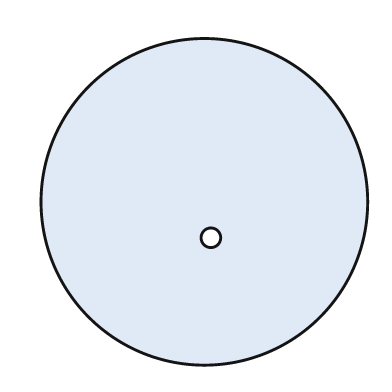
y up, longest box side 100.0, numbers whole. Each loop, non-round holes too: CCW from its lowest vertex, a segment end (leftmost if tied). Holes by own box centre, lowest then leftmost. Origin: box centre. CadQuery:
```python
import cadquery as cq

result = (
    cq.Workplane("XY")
    .moveTo(0.0, 0.0)
    .circle(50.0)
    .moveTo(2.0, -11.0)
    .circle(3.0)
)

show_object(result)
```